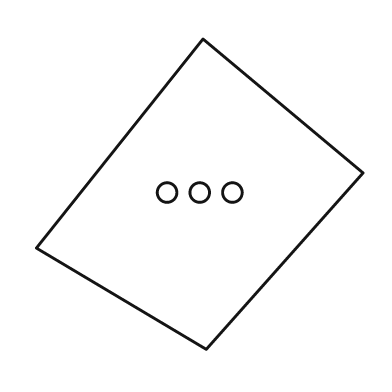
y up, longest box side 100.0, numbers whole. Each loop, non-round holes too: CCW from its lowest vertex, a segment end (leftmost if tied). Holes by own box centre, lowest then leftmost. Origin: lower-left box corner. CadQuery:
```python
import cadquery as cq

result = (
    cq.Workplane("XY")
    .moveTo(52.0, 0.0)
    .lineTo(100.0, 54.0)
    .lineTo(51.0, 95.0)
    .lineTo(0.0, 31.0)
    .close()
    .moveTo(40.0, 48.0)
    .circle(3.0)
    .moveTo(50.0, 48.0)
    .circle(3.0)
    .moveTo(60.0, 48.0)
    .circle(3.0)
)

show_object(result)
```